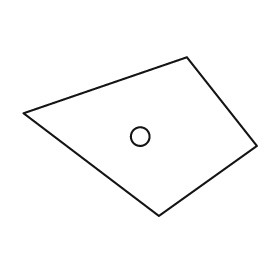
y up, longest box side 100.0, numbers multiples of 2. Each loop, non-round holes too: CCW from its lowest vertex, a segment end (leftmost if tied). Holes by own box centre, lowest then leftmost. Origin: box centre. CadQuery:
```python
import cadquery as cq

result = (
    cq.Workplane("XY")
    .moveTo(8.0, -34.0)
    .lineTo(50.0, -4.0)
    .lineTo(20.0, 34.0)
    .lineTo(-50.0, 10.0)
    .close()
    .moveTo(0.0, 0.0)
    .circle(4.0)
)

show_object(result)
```